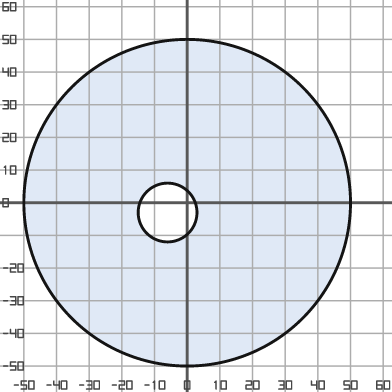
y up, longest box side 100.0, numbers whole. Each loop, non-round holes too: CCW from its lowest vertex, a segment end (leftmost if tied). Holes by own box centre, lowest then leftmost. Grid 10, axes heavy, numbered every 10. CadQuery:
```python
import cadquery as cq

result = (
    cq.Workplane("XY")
    .moveTo(0.0, 0.0)
    .circle(50.0)
    .moveTo(-6.0, -3.0)
    .circle(9.0)
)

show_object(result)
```